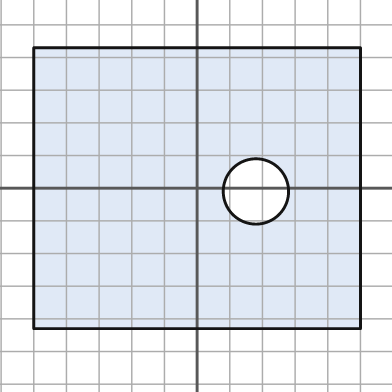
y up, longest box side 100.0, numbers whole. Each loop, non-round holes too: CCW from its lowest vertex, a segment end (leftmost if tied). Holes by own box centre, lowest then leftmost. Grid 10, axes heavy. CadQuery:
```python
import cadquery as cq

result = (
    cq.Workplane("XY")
    .moveTo(-50.0, -43.0)
    .lineTo(50.0, -43.0)
    .lineTo(50.0, 43.0)
    .lineTo(-50.0, 43.0)
    .close()
    .moveTo(18.0, -1.0)
    .circle(10.0)
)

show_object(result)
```